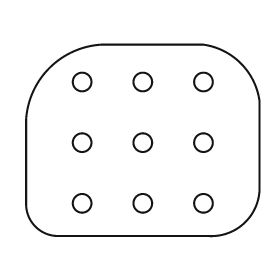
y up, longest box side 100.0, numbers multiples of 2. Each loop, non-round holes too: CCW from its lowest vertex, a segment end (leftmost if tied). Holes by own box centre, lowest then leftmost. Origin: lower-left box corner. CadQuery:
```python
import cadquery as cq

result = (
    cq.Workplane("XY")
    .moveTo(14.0, 0.0)
    .lineTo(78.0, 0.0)
    .threePointArc((94.0, 6.0), (100.0, 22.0))
    .lineTo(100.0, 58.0)
    .threePointArc((92.0, 74.0), (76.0, 82.0))
    .lineTo(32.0, 82.0)
    .threePointArc((10.0, 72.0), (0.0, 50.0))
    .lineTo(0.0, 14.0)
    .threePointArc((4.0, 4.0), (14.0, 0.0))
    .close()
    .moveTo(24.0, 14.0)
    .circle(4.0)
    .moveTo(50.0, 14.0)
    .circle(4.0)
    .moveTo(76.0, 14.0)
    .circle(4.0)
    .moveTo(24.0, 40.0)
    .circle(4.0)
    .moveTo(50.0, 40.0)
    .circle(4.0)
    .moveTo(76.0, 40.0)
    .circle(4.0)
    .moveTo(24.0, 66.0)
    .circle(4.0)
    .moveTo(50.0, 66.0)
    .circle(4.0)
    .moveTo(76.0, 66.0)
    .circle(4.0)
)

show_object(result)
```